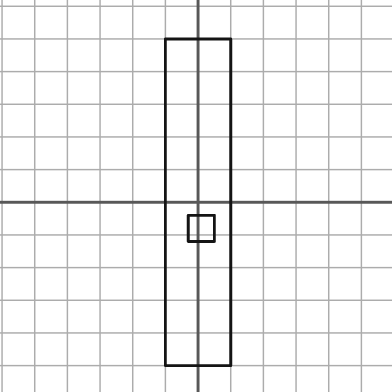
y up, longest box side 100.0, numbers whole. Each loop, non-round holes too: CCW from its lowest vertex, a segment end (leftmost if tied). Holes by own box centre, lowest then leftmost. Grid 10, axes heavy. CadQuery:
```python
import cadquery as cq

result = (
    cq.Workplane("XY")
    .moveTo(-10.0, -50.0)
    .lineTo(10.0, -50.0)
    .lineTo(10.0, 50.0)
    .lineTo(-10.0, 50.0)
    .close()
    .moveTo(-3.0, -12.0)
    .lineTo(5.0, -12.0)
    .lineTo(5.0, -4.0)
    .lineTo(-3.0, -4.0)
    .close()
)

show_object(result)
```